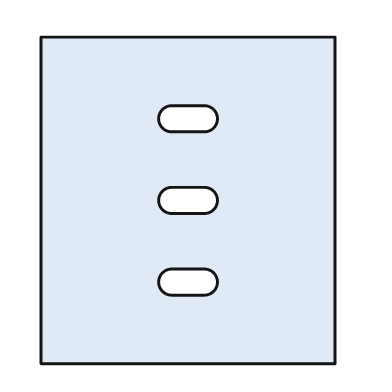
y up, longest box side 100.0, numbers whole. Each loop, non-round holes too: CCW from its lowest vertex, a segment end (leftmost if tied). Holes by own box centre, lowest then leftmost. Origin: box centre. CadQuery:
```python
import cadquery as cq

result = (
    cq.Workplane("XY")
    .moveTo(-45.0, -50.0)
    .lineTo(45.0, -50.0)
    .lineTo(45.0, 50.0)
    .lineTo(-45.0, 50.0)
    .close()
    .moveTo(-5.0, -29.0)
    .lineTo(5.0, -29.0)
    .threePointArc((9.0, -25.0), (5.0, -21.0))
    .lineTo(-5.0, -21.0)
    .threePointArc((-9.0, -25.0), (-5.0, -29.0))
    .close()
    .moveTo(-5.0, -4.0)
    .lineTo(5.0, -4.0)
    .threePointArc((9.0, 0.0), (5.0, 4.0))
    .lineTo(-5.0, 4.0)
    .threePointArc((-9.0, 0.0), (-5.0, -4.0))
    .close()
    .moveTo(-5.0, 21.0)
    .lineTo(5.0, 21.0)
    .threePointArc((9.0, 25.0), (5.0, 29.0))
    .lineTo(-5.0, 29.0)
    .threePointArc((-9.0, 25.0), (-5.0, 21.0))
    .close()
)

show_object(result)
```